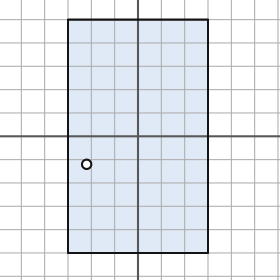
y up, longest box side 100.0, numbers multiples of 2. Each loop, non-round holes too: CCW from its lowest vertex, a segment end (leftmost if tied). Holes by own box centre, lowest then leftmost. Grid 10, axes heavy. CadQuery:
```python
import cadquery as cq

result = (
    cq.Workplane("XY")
    .moveTo(-30.0, -50.0)
    .lineTo(30.0, -50.0)
    .lineTo(30.0, 50.0)
    .lineTo(-30.0, 50.0)
    .close()
    .moveTo(-22.0, -12.0)
    .circle(2.0)
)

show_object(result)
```